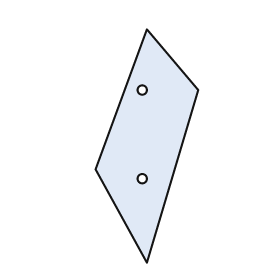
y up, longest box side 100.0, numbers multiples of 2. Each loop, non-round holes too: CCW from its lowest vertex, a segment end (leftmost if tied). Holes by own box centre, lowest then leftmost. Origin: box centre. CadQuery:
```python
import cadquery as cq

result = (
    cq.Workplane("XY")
    .moveTo(0.0, -50.0)
    .lineTo(22.0, 24.0)
    .lineTo(0.0, 50.0)
    .lineTo(-22.0, -10.0)
    .close()
    .moveTo(-2.0, -14.0)
    .circle(2.0)
    .moveTo(-2.0, 24.0)
    .circle(2.0)
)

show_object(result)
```